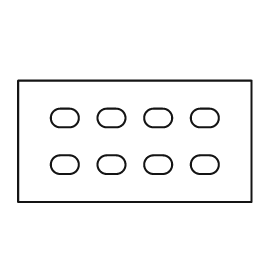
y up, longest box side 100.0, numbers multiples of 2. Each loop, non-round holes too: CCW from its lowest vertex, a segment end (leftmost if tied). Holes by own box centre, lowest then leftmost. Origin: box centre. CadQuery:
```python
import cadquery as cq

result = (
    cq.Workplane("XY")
    .moveTo(-50.0, -26.0)
    .lineTo(50.0, -26.0)
    .lineTo(50.0, 26.0)
    .lineTo(-50.0, 26.0)
    .close()
    .moveTo(-32.0, -14.0)
    .lineTo(-28.0, -14.0)
    .threePointArc((-24.0, -10.0), (-28.0, -6.0))
    .lineTo(-32.0, -6.0)
    .threePointArc((-36.0, -10.0), (-32.0, -14.0))
    .close()
    .moveTo(-12.0, -14.0)
    .lineTo(-8.0, -14.0)
    .threePointArc((-4.0, -10.0), (-8.0, -6.0))
    .lineTo(-12.0, -6.0)
    .threePointArc((-16.0, -10.0), (-12.0, -14.0))
    .close()
    .moveTo(8.0, -14.0)
    .lineTo(12.0, -14.0)
    .threePointArc((16.0, -10.0), (12.0, -6.0))
    .lineTo(8.0, -6.0)
    .threePointArc((4.0, -10.0), (8.0, -14.0))
    .close()
    .moveTo(28.0, -14.0)
    .lineTo(32.0, -14.0)
    .threePointArc((36.0, -10.0), (32.0, -6.0))
    .lineTo(28.0, -6.0)
    .threePointArc((24.0, -10.0), (28.0, -14.0))
    .close()
    .moveTo(-32.0, 6.0)
    .lineTo(-28.0, 6.0)
    .threePointArc((-24.0, 10.0), (-28.0, 14.0))
    .lineTo(-32.0, 14.0)
    .threePointArc((-36.0, 10.0), (-32.0, 6.0))
    .close()
    .moveTo(-12.0, 6.0)
    .lineTo(-8.0, 6.0)
    .threePointArc((-4.0, 10.0), (-8.0, 14.0))
    .lineTo(-12.0, 14.0)
    .threePointArc((-16.0, 10.0), (-12.0, 6.0))
    .close()
    .moveTo(8.0, 6.0)
    .lineTo(12.0, 6.0)
    .threePointArc((16.0, 10.0), (12.0, 14.0))
    .lineTo(8.0, 14.0)
    .threePointArc((4.0, 10.0), (8.0, 6.0))
    .close()
    .moveTo(28.0, 6.0)
    .lineTo(32.0, 6.0)
    .threePointArc((36.0, 10.0), (32.0, 14.0))
    .lineTo(28.0, 14.0)
    .threePointArc((24.0, 10.0), (28.0, 6.0))
    .close()
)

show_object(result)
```